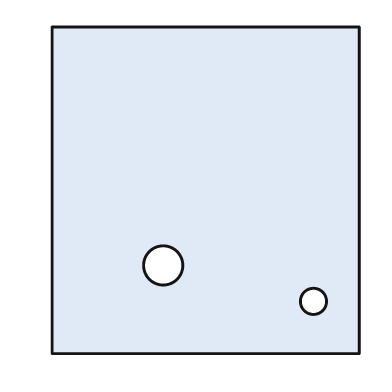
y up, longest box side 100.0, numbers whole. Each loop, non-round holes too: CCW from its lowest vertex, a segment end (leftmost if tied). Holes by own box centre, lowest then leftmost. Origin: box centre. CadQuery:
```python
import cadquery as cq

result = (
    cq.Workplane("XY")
    .moveTo(-47.0, -50.0)
    .lineTo(47.0, -50.0)
    .lineTo(47.0, 50.0)
    .lineTo(-47.0, 50.0)
    .close()
    .moveTo(33.0, -34.0)
    .circle(4.0)
    .moveTo(-13.0, -23.0)
    .circle(6.0)
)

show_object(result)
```